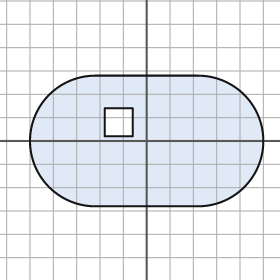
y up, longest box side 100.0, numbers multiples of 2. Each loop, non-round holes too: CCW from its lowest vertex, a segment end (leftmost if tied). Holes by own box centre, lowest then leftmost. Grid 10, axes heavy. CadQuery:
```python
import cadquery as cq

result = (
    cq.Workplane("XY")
    .moveTo(-22.0, -28.0)
    .lineTo(22.0, -28.0)
    .threePointArc((50.0, 0.0), (22.0, 28.0))
    .lineTo(-22.0, 28.0)
    .threePointArc((-50.0, 0.0), (-22.0, -28.0))
    .close()
    .moveTo(-18.0, 2.0)
    .lineTo(-6.0, 2.0)
    .lineTo(-6.0, 14.0)
    .lineTo(-18.0, 14.0)
    .close()
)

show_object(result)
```